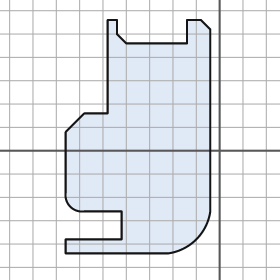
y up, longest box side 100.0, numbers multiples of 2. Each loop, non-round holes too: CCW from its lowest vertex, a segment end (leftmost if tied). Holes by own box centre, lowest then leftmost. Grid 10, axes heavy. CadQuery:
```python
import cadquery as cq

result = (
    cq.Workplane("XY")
    .moveTo(-66.0, -44.0)
    .lineTo(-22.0, -44.0)
    .threePointArc((-10.0, -38.0), (-4.0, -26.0))
    .lineTo(-4.0, 52.0)
    .lineTo(-8.0, 56.0)
    .lineTo(-14.0, 56.0)
    .lineTo(-14.0, 46.0)
    .lineTo(-40.0, 46.0)
    .lineTo(-44.0, 50.0)
    .lineTo(-44.0, 56.0)
    .lineTo(-48.0, 56.0)
    .lineTo(-48.0, 16.0)
    .lineTo(-58.0, 16.0)
    .lineTo(-66.0, 8.0)
    .lineTo(-66.0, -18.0)
    .threePointArc((-64.0, -24.0), (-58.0, -26.0))
    .lineTo(-42.0, -26.0)
    .lineTo(-42.0, -38.0)
    .lineTo(-66.0, -38.0)
    .close()
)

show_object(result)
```